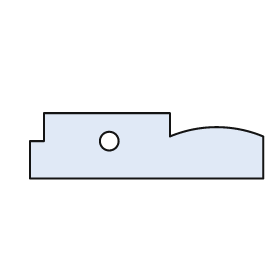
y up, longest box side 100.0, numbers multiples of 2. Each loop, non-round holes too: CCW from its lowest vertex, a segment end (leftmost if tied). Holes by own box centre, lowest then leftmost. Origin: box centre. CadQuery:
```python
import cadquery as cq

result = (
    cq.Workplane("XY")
    .moveTo(-50.0, -14.0)
    .lineTo(50.0, -14.0)
    .lineTo(50.0, 4.0)
    .threePointArc((30.0, 8.0), (10.0, 4.0))
    .lineTo(10.0, 14.0)
    .lineTo(-44.0, 14.0)
    .lineTo(-44.0, 2.0)
    .lineTo(-50.0, 2.0)
    .close()
    .moveTo(-16.0, 2.0)
    .circle(4.0)
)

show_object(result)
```